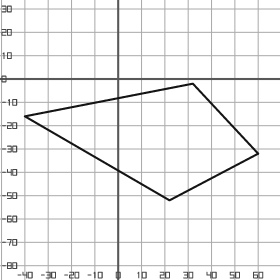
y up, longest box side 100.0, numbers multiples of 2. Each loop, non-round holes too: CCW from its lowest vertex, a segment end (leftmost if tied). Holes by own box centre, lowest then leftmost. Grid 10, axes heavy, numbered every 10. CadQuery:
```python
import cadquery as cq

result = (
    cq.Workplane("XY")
    .moveTo(22.0, -52.0)
    .lineTo(60.0, -32.0)
    .lineTo(32.0, -2.0)
    .lineTo(-40.0, -16.0)
    .close()
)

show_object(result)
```